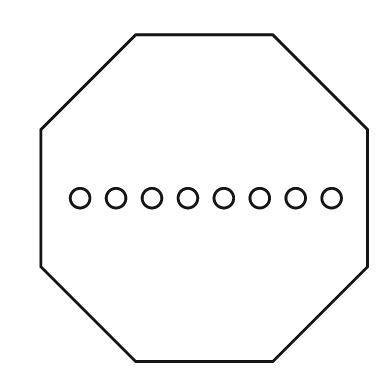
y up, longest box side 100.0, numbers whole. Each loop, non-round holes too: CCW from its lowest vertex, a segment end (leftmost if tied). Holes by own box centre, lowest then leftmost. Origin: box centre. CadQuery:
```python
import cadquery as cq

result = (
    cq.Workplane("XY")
    .moveTo(-21.0, -50.0)
    .lineTo(21.0, -50.0)
    .lineTo(50.0, -21.0)
    .lineTo(50.0, 21.0)
    .lineTo(21.0, 50.0)
    .lineTo(-21.0, 50.0)
    .lineTo(-50.0, 21.0)
    .lineTo(-50.0, -21.0)
    .close()
    .moveTo(-38.0, 0.0)
    .circle(3.0)
    .moveTo(-27.0, 0.0)
    .circle(3.0)
    .moveTo(-16.0, 0.0)
    .circle(3.0)
    .moveTo(-5.0, 0.0)
    .circle(3.0)
    .moveTo(6.0, 0.0)
    .circle(3.0)
    .moveTo(17.0, 0.0)
    .circle(3.0)
    .moveTo(28.0, 0.0)
    .circle(3.0)
    .moveTo(39.0, 0.0)
    .circle(3.0)
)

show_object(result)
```